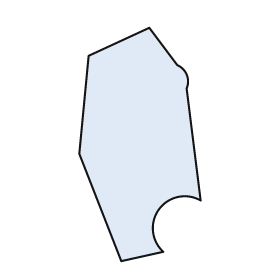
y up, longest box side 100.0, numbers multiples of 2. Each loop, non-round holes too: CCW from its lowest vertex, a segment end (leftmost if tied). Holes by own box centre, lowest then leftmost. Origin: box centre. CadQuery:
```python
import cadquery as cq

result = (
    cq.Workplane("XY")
    .moveTo(-8.0, -50.0)
    .lineTo(10.0, -46.0)
    .threePointArc((8.0, -28.0), (26.0, -24.0))
    .lineTo(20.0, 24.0)
    .threePointArc((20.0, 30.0), (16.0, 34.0))
    .lineTo(4.0, 50.0)
    .lineTo(-22.0, 38.0)
    .lineTo(-26.0, -4.0)
    .close()
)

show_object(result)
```